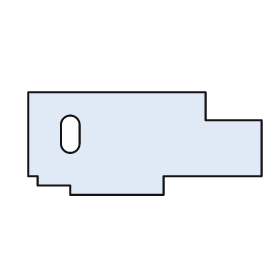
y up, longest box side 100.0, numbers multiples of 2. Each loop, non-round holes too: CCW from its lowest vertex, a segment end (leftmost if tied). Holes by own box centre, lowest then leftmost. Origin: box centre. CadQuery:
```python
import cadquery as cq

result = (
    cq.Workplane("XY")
    .moveTo(-32.0, -22.0)
    .lineTo(8.0, -22.0)
    .lineTo(8.0, -14.0)
    .lineTo(50.0, -14.0)
    .lineTo(50.0, 10.0)
    .lineTo(26.0, 10.0)
    .lineTo(26.0, 22.0)
    .lineTo(-50.0, 22.0)
    .lineTo(-50.0, -14.0)
    .lineTo(-46.0, -14.0)
    .lineTo(-46.0, -18.0)
    .lineTo(-32.0, -18.0)
    .close()
    .moveTo(-36.0, 0.0)
    .threePointArc((-32.0, -4.0), (-28.0, 0.0))
    .lineTo(-28.0, 8.0)
    .threePointArc((-32.0, 12.0), (-36.0, 8.0))
    .close()
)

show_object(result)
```